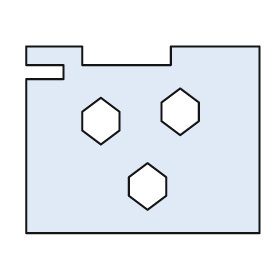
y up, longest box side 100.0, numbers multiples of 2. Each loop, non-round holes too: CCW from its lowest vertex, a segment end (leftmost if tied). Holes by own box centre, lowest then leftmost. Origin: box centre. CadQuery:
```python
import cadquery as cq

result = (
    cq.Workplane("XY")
    .moveTo(-50.0, -40.0)
    .lineTo(50.0, -40.0)
    .lineTo(50.0, 40.0)
    .lineTo(12.0, 40.0)
    .lineTo(12.0, 32.0)
    .lineTo(-26.0, 32.0)
    .lineTo(-26.0, 40.0)
    .lineTo(-50.0, 40.0)
    .lineTo(-50.0, 32.0)
    .lineTo(-34.0, 32.0)
    .lineTo(-34.0, 26.0)
    .lineTo(-50.0, 26.0)
    .close()
    .moveTo(2.0, -30.0)
    .lineTo(10.0, -24.0)
    .lineTo(10.0, -16.0)
    .lineTo(2.0, -10.0)
    .lineTo(-6.0, -16.0)
    .lineTo(-6.0, -24.0)
    .close()
    .moveTo(-18.0, -2.0)
    .lineTo(-10.0, 4.0)
    .lineTo(-10.0, 12.0)
    .lineTo(-18.0, 18.0)
    .lineTo(-26.0, 12.0)
    .lineTo(-26.0, 4.0)
    .close()
    .moveTo(16.0, 2.0)
    .lineTo(24.0, 8.0)
    .lineTo(24.0, 16.0)
    .lineTo(16.0, 22.0)
    .lineTo(8.0, 16.0)
    .lineTo(8.0, 8.0)
    .close()
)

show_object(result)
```